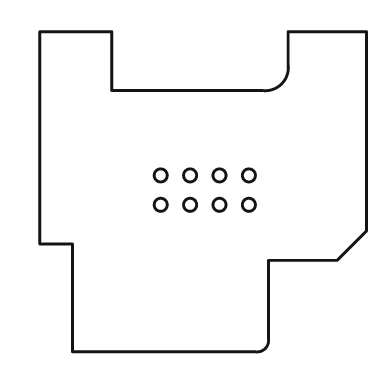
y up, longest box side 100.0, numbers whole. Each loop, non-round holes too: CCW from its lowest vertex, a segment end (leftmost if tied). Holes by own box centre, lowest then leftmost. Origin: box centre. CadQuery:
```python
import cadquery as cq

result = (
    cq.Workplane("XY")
    .moveTo(-40.0, -49.0)
    .lineTo(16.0, -49.0)
    .threePointArc((19.0, -48.0), (20.0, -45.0))
    .lineTo(20.0, -21.0)
    .lineTo(41.0, -21.0)
    .lineTo(50.0, -12.0)
    .lineTo(50.0, 49.0)
    .lineTo(26.0, 49.0)
    .lineTo(26.0, 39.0)
    .threePointArc((24.0, 33.0), (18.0, 31.0))
    .lineTo(-28.0, 31.0)
    .lineTo(-28.0, 49.0)
    .lineTo(-50.0, 49.0)
    .lineTo(-50.0, -16.0)
    .lineTo(-40.0, -16.0)
    .close()
    .moveTo(-13.0, -4.0)
    .circle(2.0)
    .moveTo(-4.0, -4.0)
    .circle(2.0)
    .moveTo(5.0, -4.0)
    .circle(2.0)
    .moveTo(14.0, -4.0)
    .circle(2.0)
    .moveTo(-13.0, 5.0)
    .circle(2.0)
    .moveTo(-4.0, 5.0)
    .circle(2.0)
    .moveTo(5.0, 5.0)
    .circle(2.0)
    .moveTo(14.0, 5.0)
    .circle(2.0)
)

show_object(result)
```